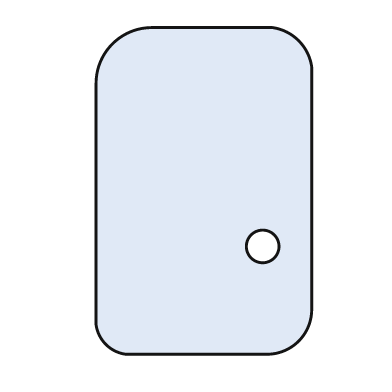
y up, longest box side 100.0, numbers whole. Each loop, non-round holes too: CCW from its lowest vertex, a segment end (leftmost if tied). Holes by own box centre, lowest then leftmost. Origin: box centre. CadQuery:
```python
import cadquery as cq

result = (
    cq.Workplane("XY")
    .moveTo(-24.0, -50.0)
    .lineTo(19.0, -50.0)
    .threePointArc((29.0, -46.0), (33.0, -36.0))
    .lineTo(33.0, 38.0)
    .threePointArc((29.0, 46.0), (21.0, 50.0))
    .lineTo(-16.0, 50.0)
    .threePointArc((-28.0, 45.0), (-33.0, 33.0))
    .lineTo(-33.0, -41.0)
    .threePointArc((-30.0, -47.0), (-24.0, -50.0))
    .close()
    .moveTo(18.0, -17.0)
    .circle(5.0)
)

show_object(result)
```